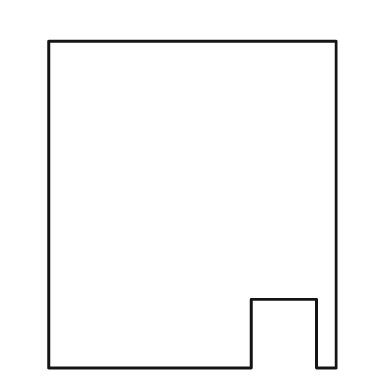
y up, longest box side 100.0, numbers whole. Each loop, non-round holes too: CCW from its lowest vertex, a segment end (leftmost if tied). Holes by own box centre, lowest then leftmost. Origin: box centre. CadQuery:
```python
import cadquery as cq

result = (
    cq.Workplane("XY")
    .moveTo(-44.0, -50.0)
    .lineTo(18.0, -50.0)
    .lineTo(18.0, -29.0)
    .lineTo(38.0, -29.0)
    .lineTo(38.0, -50.0)
    .lineTo(44.0, -50.0)
    .lineTo(44.0, 50.0)
    .lineTo(-44.0, 50.0)
    .close()
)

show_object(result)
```